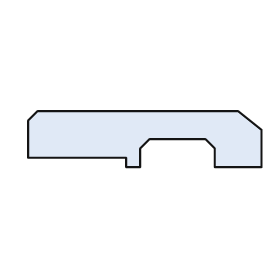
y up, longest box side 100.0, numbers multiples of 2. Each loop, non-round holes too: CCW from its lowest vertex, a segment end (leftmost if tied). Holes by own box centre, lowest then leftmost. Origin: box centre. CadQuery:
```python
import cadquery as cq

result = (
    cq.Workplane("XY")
    .moveTo(-8.0, -12.0)
    .lineTo(-2.0, -12.0)
    .lineTo(-2.0, -4.0)
    .lineTo(2.0, 0.0)
    .lineTo(26.0, 0.0)
    .lineTo(30.0, -4.0)
    .lineTo(30.0, -12.0)
    .lineTo(50.0, -12.0)
    .lineTo(50.0, 4.0)
    .lineTo(40.0, 12.0)
    .lineTo(-46.0, 12.0)
    .lineTo(-50.0, 8.0)
    .lineTo(-50.0, -8.0)
    .lineTo(-8.0, -8.0)
    .close()
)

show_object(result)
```